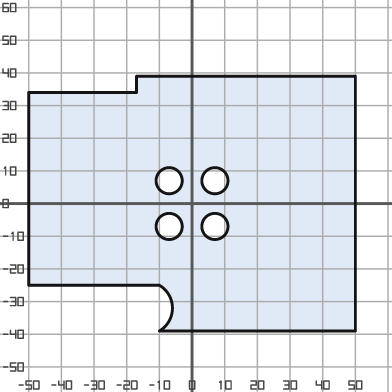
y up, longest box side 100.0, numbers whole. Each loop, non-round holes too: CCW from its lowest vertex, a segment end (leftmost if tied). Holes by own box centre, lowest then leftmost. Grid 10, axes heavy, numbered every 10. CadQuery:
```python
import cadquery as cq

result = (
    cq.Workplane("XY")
    .moveTo(-10.0, -39.0)
    .lineTo(50.0, -39.0)
    .lineTo(50.0, 39.0)
    .lineTo(-17.0, 39.0)
    .lineTo(-17.0, 34.0)
    .lineTo(-50.0, 34.0)
    .lineTo(-50.0, -25.0)
    .lineTo(-10.0, -25.0)
    .threePointArc((-6.0, -32.0), (-10.0, -39.0))
    .close()
    .moveTo(-7.0, -7.0)
    .circle(4.0)
    .moveTo(7.0, -7.0)
    .circle(4.0)
    .moveTo(-7.0, 7.0)
    .circle(4.0)
    .moveTo(7.0, 7.0)
    .circle(4.0)
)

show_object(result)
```